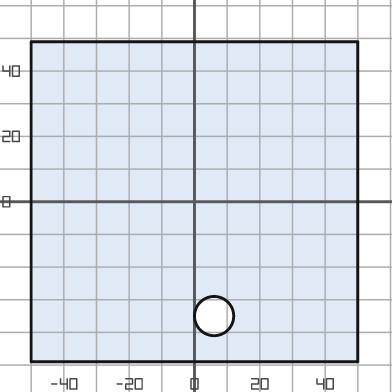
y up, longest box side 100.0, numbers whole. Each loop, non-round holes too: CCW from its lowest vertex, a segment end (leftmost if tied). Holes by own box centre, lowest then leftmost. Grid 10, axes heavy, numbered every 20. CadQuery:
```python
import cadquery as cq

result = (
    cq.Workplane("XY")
    .moveTo(-50.0, -49.0)
    .lineTo(50.0, -49.0)
    .lineTo(50.0, 49.0)
    .lineTo(-50.0, 49.0)
    .close()
    .moveTo(6.0, -35.0)
    .circle(6.0)
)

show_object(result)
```